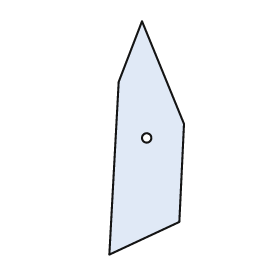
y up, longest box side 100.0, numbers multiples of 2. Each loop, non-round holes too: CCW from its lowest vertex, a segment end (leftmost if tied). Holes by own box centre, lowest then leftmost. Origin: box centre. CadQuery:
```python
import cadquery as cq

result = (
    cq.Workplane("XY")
    .moveTo(-16.0, -50.0)
    .lineTo(14.0, -36.0)
    .lineTo(16.0, 6.0)
    .lineTo(-2.0, 50.0)
    .lineTo(-12.0, 24.0)
    .close()
    .moveTo(0.0, 0.0)
    .circle(2.0)
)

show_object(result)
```